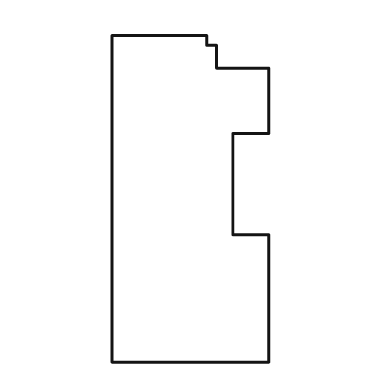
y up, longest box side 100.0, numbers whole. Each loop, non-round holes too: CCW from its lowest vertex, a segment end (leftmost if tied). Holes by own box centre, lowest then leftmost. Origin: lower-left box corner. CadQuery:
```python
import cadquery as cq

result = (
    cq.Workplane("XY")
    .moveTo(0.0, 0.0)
    .lineTo(48.0, 0.0)
    .lineTo(48.0, 39.0)
    .lineTo(37.0, 39.0)
    .lineTo(37.0, 70.0)
    .lineTo(48.0, 70.0)
    .lineTo(48.0, 90.0)
    .lineTo(32.0, 90.0)
    .lineTo(32.0, 97.0)
    .lineTo(29.0, 97.0)
    .lineTo(29.0, 100.0)
    .lineTo(0.0, 100.0)
    .close()
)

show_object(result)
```